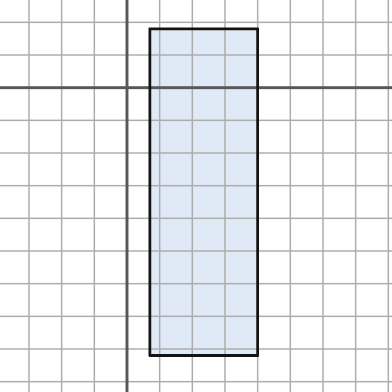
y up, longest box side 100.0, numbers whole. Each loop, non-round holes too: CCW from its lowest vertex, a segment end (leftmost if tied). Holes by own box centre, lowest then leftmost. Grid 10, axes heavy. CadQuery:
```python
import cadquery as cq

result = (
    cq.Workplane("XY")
    .moveTo(7.0, -82.0)
    .lineTo(40.0, -82.0)
    .lineTo(40.0, 18.0)
    .lineTo(7.0, 18.0)
    .close()
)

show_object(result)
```